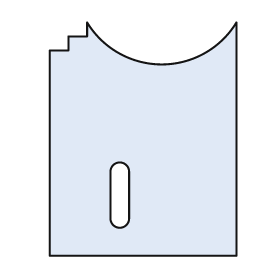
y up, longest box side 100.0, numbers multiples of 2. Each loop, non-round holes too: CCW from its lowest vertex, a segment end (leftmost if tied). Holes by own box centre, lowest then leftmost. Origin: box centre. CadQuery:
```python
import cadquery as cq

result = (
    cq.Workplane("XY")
    .moveTo(-40.0, -50.0)
    .lineTo(40.0, -50.0)
    .lineTo(40.0, 50.0)
    .threePointArc((8.0, 32.0), (-24.0, 50.0))
    .lineTo(-24.0, 44.0)
    .lineTo(-32.0, 44.0)
    .lineTo(-32.0, 38.0)
    .lineTo(-40.0, 38.0)
    .close()
    .moveTo(-14.0, -34.0)
    .threePointArc((-10.0, -38.0), (-6.0, -34.0))
    .lineTo(-6.0, -14.0)
    .threePointArc((-10.0, -10.0), (-14.0, -14.0))
    .close()
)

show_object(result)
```